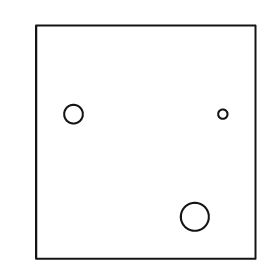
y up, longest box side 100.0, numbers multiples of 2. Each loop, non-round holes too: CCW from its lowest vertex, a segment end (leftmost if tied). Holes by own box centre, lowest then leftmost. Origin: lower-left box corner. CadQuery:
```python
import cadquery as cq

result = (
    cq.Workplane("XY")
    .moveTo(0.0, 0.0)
    .lineTo(94.0, 0.0)
    .lineTo(94.0, 100.0)
    .lineTo(0.0, 100.0)
    .close()
    .moveTo(68.0, 18.0)
    .circle(6.0)
    .moveTo(16.0, 62.0)
    .circle(4.0)
    .moveTo(80.0, 62.0)
    .circle(2.0)
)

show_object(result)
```